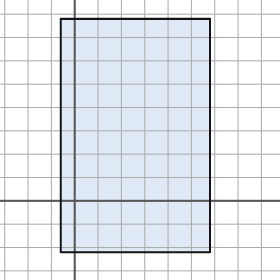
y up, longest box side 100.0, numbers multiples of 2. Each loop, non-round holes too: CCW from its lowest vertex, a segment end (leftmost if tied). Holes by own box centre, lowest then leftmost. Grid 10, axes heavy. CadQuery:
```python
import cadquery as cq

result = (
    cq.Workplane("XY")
    .moveTo(-6.0, -22.0)
    .lineTo(58.0, -22.0)
    .lineTo(58.0, 78.0)
    .lineTo(-6.0, 78.0)
    .close()
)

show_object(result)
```